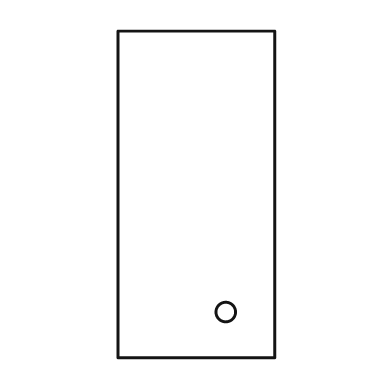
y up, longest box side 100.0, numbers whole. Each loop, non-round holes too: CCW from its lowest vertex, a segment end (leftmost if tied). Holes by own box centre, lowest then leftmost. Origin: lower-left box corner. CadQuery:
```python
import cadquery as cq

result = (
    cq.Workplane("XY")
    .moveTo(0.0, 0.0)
    .lineTo(48.0, 0.0)
    .lineTo(48.0, 100.0)
    .lineTo(0.0, 100.0)
    .close()
    .moveTo(33.0, 14.0)
    .circle(3.0)
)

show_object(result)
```